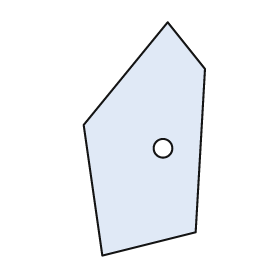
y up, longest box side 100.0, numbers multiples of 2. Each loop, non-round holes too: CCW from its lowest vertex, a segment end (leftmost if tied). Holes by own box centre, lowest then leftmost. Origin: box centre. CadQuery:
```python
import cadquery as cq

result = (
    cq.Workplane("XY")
    .moveTo(-18.0, -50.0)
    .lineTo(22.0, -40.0)
    .lineTo(26.0, 30.0)
    .lineTo(10.0, 50.0)
    .lineTo(-26.0, 6.0)
    .close()
    .moveTo(8.0, -4.0)
    .circle(4.0)
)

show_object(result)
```